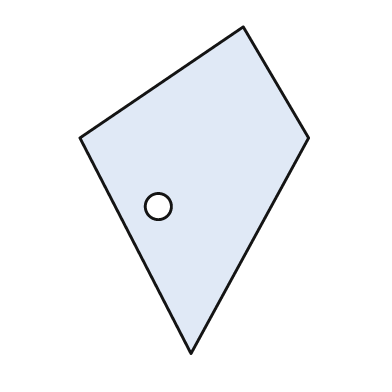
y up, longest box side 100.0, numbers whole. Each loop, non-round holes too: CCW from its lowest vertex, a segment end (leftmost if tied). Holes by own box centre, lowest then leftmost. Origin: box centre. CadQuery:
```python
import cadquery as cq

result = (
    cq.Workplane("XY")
    .moveTo(-1.0, -50.0)
    .lineTo(35.0, 16.0)
    .lineTo(15.0, 50.0)
    .lineTo(-35.0, 16.0)
    .close()
    .moveTo(-11.0, -5.0)
    .circle(4.0)
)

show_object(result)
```